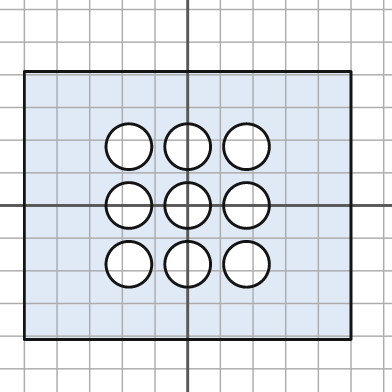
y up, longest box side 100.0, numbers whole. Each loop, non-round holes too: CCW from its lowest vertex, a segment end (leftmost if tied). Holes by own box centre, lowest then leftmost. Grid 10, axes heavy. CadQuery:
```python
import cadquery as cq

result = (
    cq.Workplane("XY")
    .moveTo(-50.0, -41.0)
    .lineTo(50.0, -41.0)
    .lineTo(50.0, 41.0)
    .lineTo(-50.0, 41.0)
    .close()
    .moveTo(-18.0, -18.0)
    .circle(7.0)
    .moveTo(0.0, -18.0)
    .circle(7.0)
    .moveTo(18.0, -18.0)
    .circle(7.0)
    .moveTo(-18.0, 0.0)
    .circle(7.0)
    .moveTo(0.0, 0.0)
    .circle(7.0)
    .moveTo(18.0, 0.0)
    .circle(7.0)
    .moveTo(-18.0, 18.0)
    .circle(7.0)
    .moveTo(0.0, 18.0)
    .circle(7.0)
    .moveTo(18.0, 18.0)
    .circle(7.0)
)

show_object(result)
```